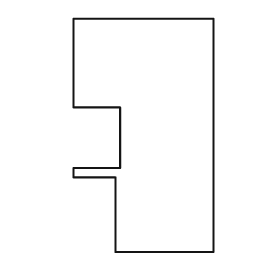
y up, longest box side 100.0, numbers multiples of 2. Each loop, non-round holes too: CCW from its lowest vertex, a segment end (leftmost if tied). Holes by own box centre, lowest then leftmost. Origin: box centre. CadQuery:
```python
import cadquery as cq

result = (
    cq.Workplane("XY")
    .moveTo(-12.0, -50.0)
    .lineTo(30.0, -50.0)
    .lineTo(30.0, 50.0)
    .lineTo(-30.0, 50.0)
    .lineTo(-30.0, 12.0)
    .lineTo(-10.0, 12.0)
    .lineTo(-10.0, -14.0)
    .lineTo(-30.0, -14.0)
    .lineTo(-30.0, -18.0)
    .lineTo(-12.0, -18.0)
    .close()
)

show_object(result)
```